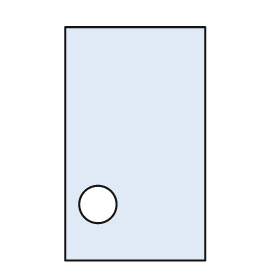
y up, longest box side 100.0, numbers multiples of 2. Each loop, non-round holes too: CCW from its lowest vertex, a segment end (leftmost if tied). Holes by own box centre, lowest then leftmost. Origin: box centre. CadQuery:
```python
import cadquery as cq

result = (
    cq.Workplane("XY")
    .moveTo(-30.0, -50.0)
    .lineTo(30.0, -50.0)
    .lineTo(30.0, 50.0)
    .lineTo(-30.0, 50.0)
    .close()
    .moveTo(-16.0, -26.0)
    .circle(8.0)
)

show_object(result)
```